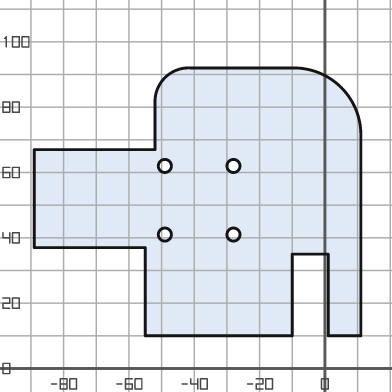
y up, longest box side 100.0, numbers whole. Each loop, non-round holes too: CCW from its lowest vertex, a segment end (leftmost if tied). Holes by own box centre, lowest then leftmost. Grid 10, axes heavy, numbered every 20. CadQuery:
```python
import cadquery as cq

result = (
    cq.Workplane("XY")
    .moveTo(-55.0, 10.0)
    .lineTo(-10.0, 10.0)
    .lineTo(-10.0, 35.0)
    .lineTo(1.0, 35.0)
    .lineTo(1.0, 10.0)
    .lineTo(11.0, 10.0)
    .lineTo(11.0, 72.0)
    .threePointArc((5.0, 86.0), (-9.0, 92.0))
    .lineTo(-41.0, 92.0)
    .threePointArc((-49.0, 89.0), (-52.0, 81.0))
    .lineTo(-52.0, 67.0)
    .lineTo(-89.0, 67.0)
    .lineTo(-89.0, 37.0)
    .lineTo(-55.0, 37.0)
    .close()
    .moveTo(-49.0, 41.0)
    .circle(2.0)
    .moveTo(-28.0, 41.0)
    .circle(2.0)
    .moveTo(-49.0, 62.0)
    .circle(2.0)
    .moveTo(-28.0, 62.0)
    .circle(2.0)
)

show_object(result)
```